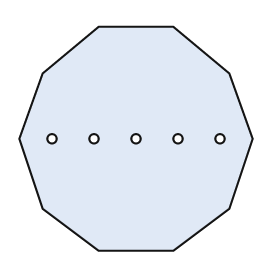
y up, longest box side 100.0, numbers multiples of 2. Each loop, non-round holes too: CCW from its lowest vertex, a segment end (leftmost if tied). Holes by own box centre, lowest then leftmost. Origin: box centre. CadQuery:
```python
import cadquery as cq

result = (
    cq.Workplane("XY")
    .moveTo(-16.0, -48.0)
    .lineTo(16.0, -48.0)
    .lineTo(40.0, -30.0)
    .lineTo(50.0, 0.0)
    .lineTo(40.0, 28.0)
    .lineTo(16.0, 48.0)
    .lineTo(-16.0, 48.0)
    .lineTo(-40.0, 28.0)
    .lineTo(-50.0, 0.0)
    .lineTo(-40.0, -30.0)
    .close()
    .moveTo(-36.0, 0.0)
    .circle(2.0)
    .moveTo(-18.0, 0.0)
    .circle(2.0)
    .moveTo(0.0, 0.0)
    .circle(2.0)
    .moveTo(18.0, 0.0)
    .circle(2.0)
    .moveTo(36.0, 0.0)
    .circle(2.0)
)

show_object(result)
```